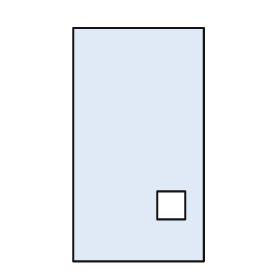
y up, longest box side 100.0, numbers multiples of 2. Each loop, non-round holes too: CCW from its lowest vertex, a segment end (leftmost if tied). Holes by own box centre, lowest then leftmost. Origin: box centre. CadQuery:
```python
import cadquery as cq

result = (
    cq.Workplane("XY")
    .moveTo(-28.0, -50.0)
    .lineTo(28.0, -50.0)
    .lineTo(28.0, 50.0)
    .lineTo(-28.0, 50.0)
    .close()
    .moveTo(8.0, -32.0)
    .lineTo(20.0, -32.0)
    .lineTo(20.0, -20.0)
    .lineTo(8.0, -20.0)
    .close()
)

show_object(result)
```